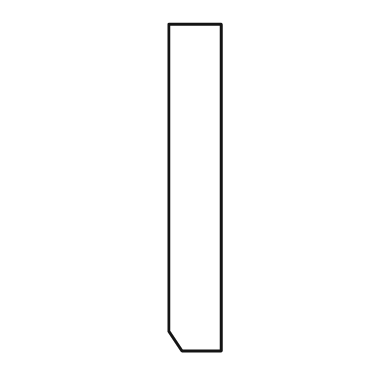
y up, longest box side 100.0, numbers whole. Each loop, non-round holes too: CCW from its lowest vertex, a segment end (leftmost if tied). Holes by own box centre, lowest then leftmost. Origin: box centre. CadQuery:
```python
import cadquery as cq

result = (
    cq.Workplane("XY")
    .moveTo(-4.0, -50.0)
    .lineTo(8.0, -50.0)
    .lineTo(8.0, 50.0)
    .lineTo(-8.0, 50.0)
    .lineTo(-8.0, -44.0)
    .close()
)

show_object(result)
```